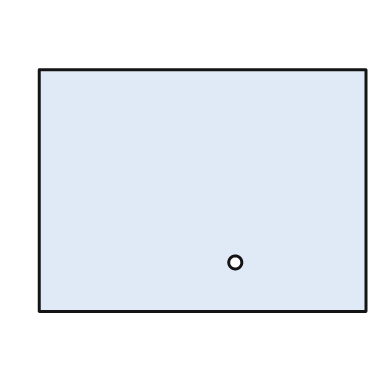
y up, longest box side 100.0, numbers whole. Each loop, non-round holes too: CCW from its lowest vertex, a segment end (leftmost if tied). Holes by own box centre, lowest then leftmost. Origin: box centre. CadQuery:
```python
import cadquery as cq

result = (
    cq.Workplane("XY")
    .moveTo(-50.0, -37.0)
    .lineTo(50.0, -37.0)
    .lineTo(50.0, 37.0)
    .lineTo(-50.0, 37.0)
    .close()
    .moveTo(10.0, -22.0)
    .circle(2.0)
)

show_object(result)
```